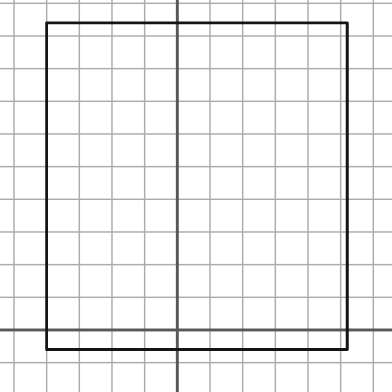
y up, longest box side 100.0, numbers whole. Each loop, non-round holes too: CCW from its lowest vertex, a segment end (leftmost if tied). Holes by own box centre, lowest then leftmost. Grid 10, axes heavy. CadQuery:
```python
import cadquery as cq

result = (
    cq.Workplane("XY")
    .moveTo(-40.0, -6.0)
    .lineTo(52.0, -6.0)
    .lineTo(52.0, 94.0)
    .lineTo(-40.0, 94.0)
    .close()
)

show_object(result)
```